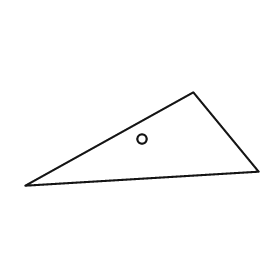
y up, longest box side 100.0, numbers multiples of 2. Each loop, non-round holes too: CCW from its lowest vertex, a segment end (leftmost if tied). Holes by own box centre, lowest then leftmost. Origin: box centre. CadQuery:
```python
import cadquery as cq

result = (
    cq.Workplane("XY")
    .moveTo(-50.0, -20.0)
    .lineTo(50.0, -14.0)
    .lineTo(22.0, 20.0)
    .close()
    .moveTo(0.0, 0.0)
    .circle(2.0)
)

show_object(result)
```